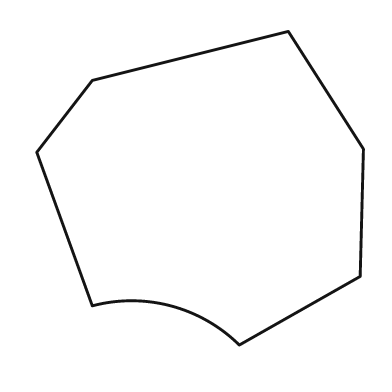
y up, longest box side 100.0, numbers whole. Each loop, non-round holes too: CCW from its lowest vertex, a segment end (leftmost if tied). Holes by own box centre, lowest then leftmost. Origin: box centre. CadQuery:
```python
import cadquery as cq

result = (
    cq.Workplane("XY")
    .moveTo(12.0, -48.0)
    .lineTo(49.0, -27.0)
    .lineTo(50.0, 12.0)
    .lineTo(27.0, 48.0)
    .lineTo(-33.0, 33.0)
    .lineTo(-50.0, 11.0)
    .lineTo(-33.0, -36.0)
    .threePointArc((-9.0, -36.0), (12.0, -48.0))
    .close()
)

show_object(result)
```